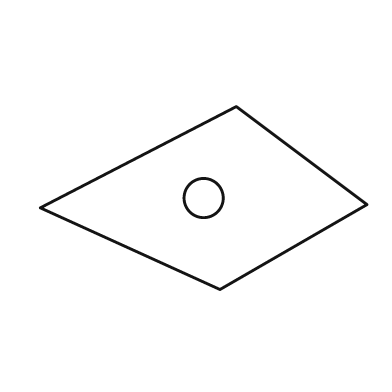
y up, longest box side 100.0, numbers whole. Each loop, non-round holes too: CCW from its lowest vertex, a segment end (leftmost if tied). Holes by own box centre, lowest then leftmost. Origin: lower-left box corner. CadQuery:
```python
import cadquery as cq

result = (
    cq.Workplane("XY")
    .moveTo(55.0, 0.0)
    .lineTo(100.0, 26.0)
    .lineTo(60.0, 56.0)
    .lineTo(0.0, 25.0)
    .close()
    .moveTo(50.0, 28.0)
    .circle(6.0)
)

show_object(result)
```